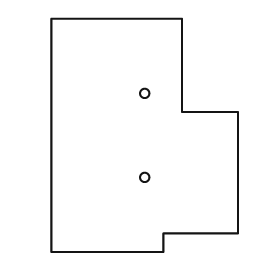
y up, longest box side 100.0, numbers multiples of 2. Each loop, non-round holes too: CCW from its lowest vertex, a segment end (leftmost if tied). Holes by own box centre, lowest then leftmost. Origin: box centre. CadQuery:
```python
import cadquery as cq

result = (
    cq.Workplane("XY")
    .moveTo(-40.0, -50.0)
    .lineTo(8.0, -50.0)
    .lineTo(8.0, -42.0)
    .lineTo(40.0, -42.0)
    .lineTo(40.0, 10.0)
    .lineTo(16.0, 10.0)
    .lineTo(16.0, 50.0)
    .lineTo(-40.0, 50.0)
    .close()
    .moveTo(0.0, -18.0)
    .circle(2.0)
    .moveTo(0.0, 18.0)
    .circle(2.0)
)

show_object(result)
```